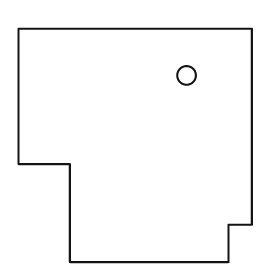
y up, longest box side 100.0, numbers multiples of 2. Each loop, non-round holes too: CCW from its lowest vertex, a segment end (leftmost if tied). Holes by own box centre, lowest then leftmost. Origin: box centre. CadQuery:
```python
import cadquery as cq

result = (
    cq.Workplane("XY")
    .moveTo(-28.0, -50.0)
    .lineTo(40.0, -50.0)
    .lineTo(40.0, -34.0)
    .lineTo(50.0, -34.0)
    .lineTo(50.0, 50.0)
    .lineTo(-50.0, 50.0)
    .lineTo(-50.0, -8.0)
    .lineTo(-28.0, -8.0)
    .close()
    .moveTo(22.0, 30.0)
    .circle(4.0)
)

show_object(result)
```